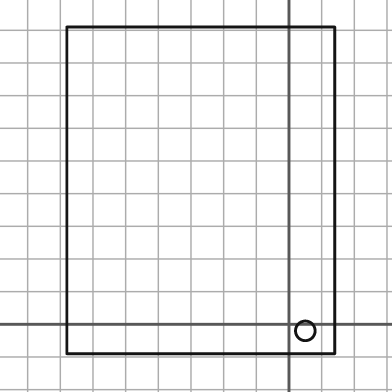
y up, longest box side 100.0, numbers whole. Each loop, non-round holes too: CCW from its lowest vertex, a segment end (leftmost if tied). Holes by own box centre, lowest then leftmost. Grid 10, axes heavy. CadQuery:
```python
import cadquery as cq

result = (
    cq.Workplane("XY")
    .moveTo(-68.0, -9.0)
    .lineTo(14.0, -9.0)
    .lineTo(14.0, 91.0)
    .lineTo(-68.0, 91.0)
    .close()
    .moveTo(5.0, -2.0)
    .circle(3.0)
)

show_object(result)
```